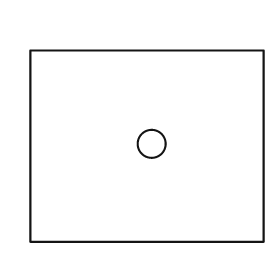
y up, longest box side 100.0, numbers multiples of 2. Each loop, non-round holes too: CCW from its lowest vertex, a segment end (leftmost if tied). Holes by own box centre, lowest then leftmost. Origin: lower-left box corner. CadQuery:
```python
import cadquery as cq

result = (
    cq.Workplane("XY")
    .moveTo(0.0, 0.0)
    .lineTo(100.0, 0.0)
    .lineTo(100.0, 82.0)
    .lineTo(0.0, 82.0)
    .close()
    .moveTo(52.0, 42.0)
    .circle(6.0)
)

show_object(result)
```